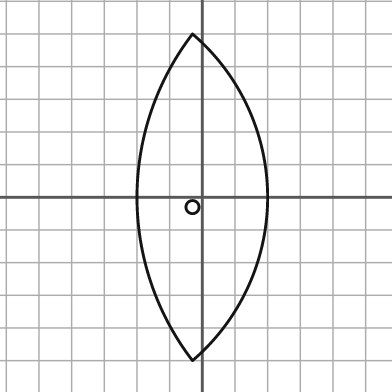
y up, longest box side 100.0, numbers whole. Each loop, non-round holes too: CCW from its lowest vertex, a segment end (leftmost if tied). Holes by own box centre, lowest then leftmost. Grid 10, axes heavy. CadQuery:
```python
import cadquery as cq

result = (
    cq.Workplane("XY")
    .moveTo(-3.0, -50.0)
    .threePointArc((20.0, 0.0), (-3.0, 50.0))
    .threePointArc((-20.0, 0.0), (-3.0, -50.0))
    .close()
    .moveTo(-3.0, -3.0)
    .circle(2.0)
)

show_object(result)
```